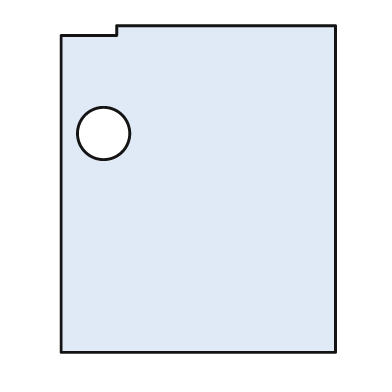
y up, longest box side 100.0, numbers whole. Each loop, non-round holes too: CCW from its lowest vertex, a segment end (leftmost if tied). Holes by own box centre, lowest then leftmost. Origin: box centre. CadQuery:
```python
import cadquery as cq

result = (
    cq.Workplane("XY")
    .moveTo(-42.0, -50.0)
    .lineTo(42.0, -50.0)
    .lineTo(42.0, 50.0)
    .lineTo(-25.0, 50.0)
    .lineTo(-25.0, 47.0)
    .lineTo(-42.0, 47.0)
    .close()
    .moveTo(-29.0, 17.0)
    .circle(8.0)
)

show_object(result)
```